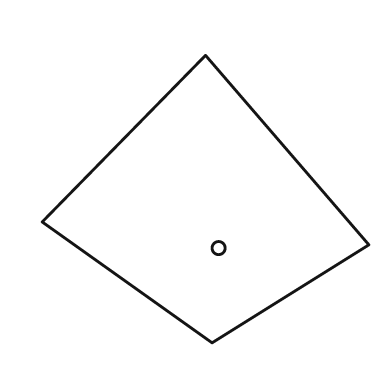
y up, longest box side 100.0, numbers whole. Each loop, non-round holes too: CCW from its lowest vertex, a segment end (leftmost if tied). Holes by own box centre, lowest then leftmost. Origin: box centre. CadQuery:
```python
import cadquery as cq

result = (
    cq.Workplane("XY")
    .moveTo(2.0, -44.0)
    .lineTo(50.0, -14.0)
    .lineTo(0.0, 44.0)
    .lineTo(-50.0, -7.0)
    .close()
    .moveTo(4.0, -15.0)
    .circle(2.0)
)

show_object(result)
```